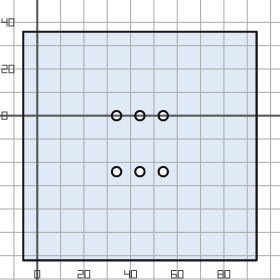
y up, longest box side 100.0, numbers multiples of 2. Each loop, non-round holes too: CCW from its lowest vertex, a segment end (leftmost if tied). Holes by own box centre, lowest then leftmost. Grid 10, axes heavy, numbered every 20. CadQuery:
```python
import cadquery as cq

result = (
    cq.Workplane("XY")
    .moveTo(-6.0, -62.0)
    .lineTo(94.0, -62.0)
    .lineTo(94.0, 36.0)
    .lineTo(-6.0, 36.0)
    .close()
    .moveTo(34.0, -24.0)
    .circle(2.0)
    .moveTo(44.0, -24.0)
    .circle(2.0)
    .moveTo(54.0, -24.0)
    .circle(2.0)
    .moveTo(34.0, 0.0)
    .circle(2.0)
    .moveTo(44.0, 0.0)
    .circle(2.0)
    .moveTo(54.0, 0.0)
    .circle(2.0)
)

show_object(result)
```